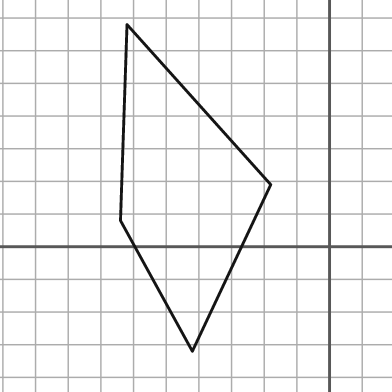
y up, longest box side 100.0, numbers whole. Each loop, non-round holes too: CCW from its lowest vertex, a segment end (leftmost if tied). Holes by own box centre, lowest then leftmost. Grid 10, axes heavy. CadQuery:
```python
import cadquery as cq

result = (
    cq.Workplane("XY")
    .moveTo(-42.0, -32.0)
    .lineTo(-18.0, 19.0)
    .lineTo(-62.0, 68.0)
    .lineTo(-64.0, 8.0)
    .close()
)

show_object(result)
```